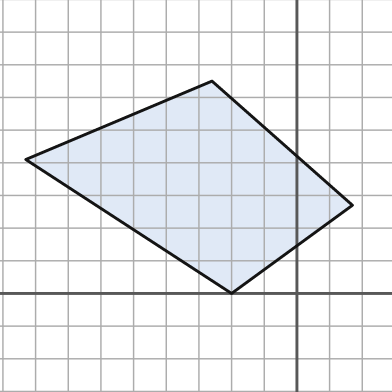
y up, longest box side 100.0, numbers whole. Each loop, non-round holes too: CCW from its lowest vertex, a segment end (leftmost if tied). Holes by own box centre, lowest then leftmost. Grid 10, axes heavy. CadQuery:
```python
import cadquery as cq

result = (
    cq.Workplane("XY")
    .moveTo(-20.0, 0.0)
    .lineTo(17.0, 27.0)
    .lineTo(-26.0, 65.0)
    .lineTo(-83.0, 41.0)
    .close()
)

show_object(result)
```